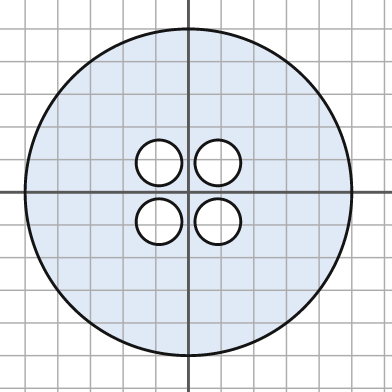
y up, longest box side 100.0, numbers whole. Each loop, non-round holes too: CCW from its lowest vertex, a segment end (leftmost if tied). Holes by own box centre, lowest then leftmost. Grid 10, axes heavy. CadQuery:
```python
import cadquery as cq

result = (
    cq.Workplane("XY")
    .moveTo(0.0, 0.0)
    .circle(50.0)
    .moveTo(-9.0, -9.0)
    .circle(7.0)
    .moveTo(9.0, -9.0)
    .circle(7.0)
    .moveTo(-9.0, 9.0)
    .circle(7.0)
    .moveTo(9.0, 9.0)
    .circle(7.0)
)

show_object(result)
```